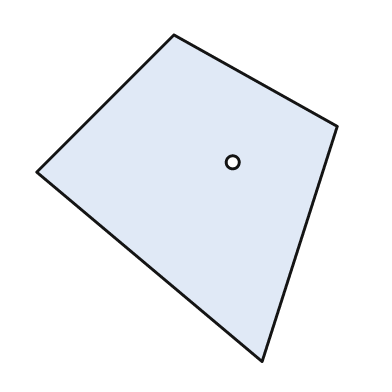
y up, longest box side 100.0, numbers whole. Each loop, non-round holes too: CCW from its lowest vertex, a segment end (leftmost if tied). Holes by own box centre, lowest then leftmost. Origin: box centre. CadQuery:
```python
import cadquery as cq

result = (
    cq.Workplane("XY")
    .moveTo(23.0, -50.0)
    .lineTo(46.0, 22.0)
    .lineTo(-4.0, 50.0)
    .lineTo(-46.0, 8.0)
    .close()
    .moveTo(14.0, 11.0)
    .circle(2.0)
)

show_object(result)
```